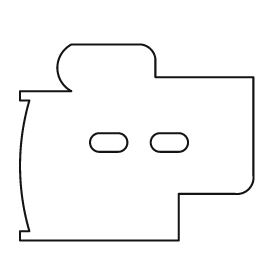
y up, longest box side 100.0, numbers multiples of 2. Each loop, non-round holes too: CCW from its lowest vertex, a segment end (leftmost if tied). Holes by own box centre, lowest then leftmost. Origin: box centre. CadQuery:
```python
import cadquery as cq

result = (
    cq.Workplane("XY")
    .moveTo(-50.0, -42.0)
    .lineTo(18.0, -42.0)
    .lineTo(18.0, -22.0)
    .lineTo(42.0, -22.0)
    .threePointArc((48.0, -20.0), (50.0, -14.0))
    .lineTo(50.0, 28.0)
    .lineTo(8.0, 28.0)
    .lineTo(8.0, 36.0)
    .threePointArc((6.0, 40.0), (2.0, 42.0))
    .lineTo(-28.0, 42.0)
    .threePointArc((-34.0, 32.0), (-28.0, 22.0))
    .lineTo(-50.0, 22.0)
    .lineTo(-50.0, 18.0)
    .lineTo(-46.0, 18.0)
    .threePointArc((-50.0, -10.0), (-46.0, -38.0))
    .lineTo(-50.0, -38.0)
    .close()
    .moveTo(-16.0, -4.0)
    .lineTo(-8.0, -4.0)
    .threePointArc((-4.0, 0.0), (-8.0, 4.0))
    .lineTo(-16.0, 4.0)
    .threePointArc((-20.0, 0.0), (-16.0, -4.0))
    .close()
    .moveTo(10.0, -4.0)
    .lineTo(18.0, -4.0)
    .threePointArc((22.0, 0.0), (18.0, 4.0))
    .lineTo(10.0, 4.0)
    .threePointArc((6.0, 0.0), (10.0, -4.0))
    .close()
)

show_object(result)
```